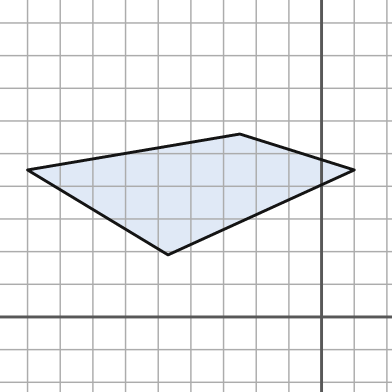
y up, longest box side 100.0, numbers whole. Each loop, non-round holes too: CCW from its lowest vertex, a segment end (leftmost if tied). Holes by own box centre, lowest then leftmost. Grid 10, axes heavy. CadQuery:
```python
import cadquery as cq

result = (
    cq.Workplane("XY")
    .moveTo(-47.0, 19.0)
    .lineTo(10.0, 45.0)
    .lineTo(-25.0, 56.0)
    .lineTo(-90.0, 45.0)
    .close()
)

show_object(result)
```